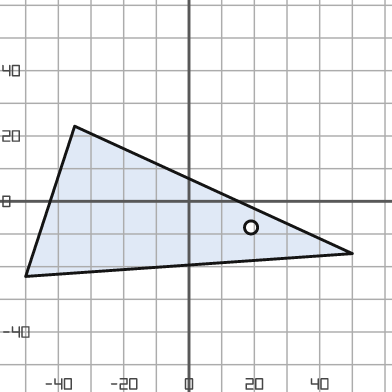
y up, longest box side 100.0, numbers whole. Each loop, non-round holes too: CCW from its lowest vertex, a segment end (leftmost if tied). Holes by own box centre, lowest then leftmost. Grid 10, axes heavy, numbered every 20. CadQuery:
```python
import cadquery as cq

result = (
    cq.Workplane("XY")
    .moveTo(-50.0, -23.0)
    .lineTo(50.0, -16.0)
    .lineTo(-35.0, 23.0)
    .close()
    .moveTo(19.0, -8.0)
    .circle(2.0)
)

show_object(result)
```